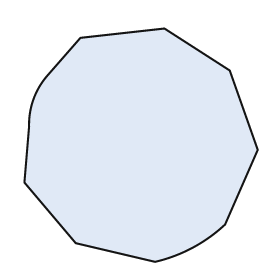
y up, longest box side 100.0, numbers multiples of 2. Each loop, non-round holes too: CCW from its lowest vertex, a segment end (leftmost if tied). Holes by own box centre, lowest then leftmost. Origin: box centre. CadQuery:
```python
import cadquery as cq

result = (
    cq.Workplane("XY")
    .moveTo(6.0, -50.0)
    .threePointArc((22.0, -44.0), (36.0, -34.0))
    .lineTo(50.0, -2.0)
    .lineTo(38.0, 32.0)
    .lineTo(10.0, 50.0)
    .lineTo(-26.0, 46.0)
    .lineTo(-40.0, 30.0)
    .threePointArc((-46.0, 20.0), (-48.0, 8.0))
    .lineTo(-50.0, -16.0)
    .lineTo(-28.0, -42.0)
    .close()
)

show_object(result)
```